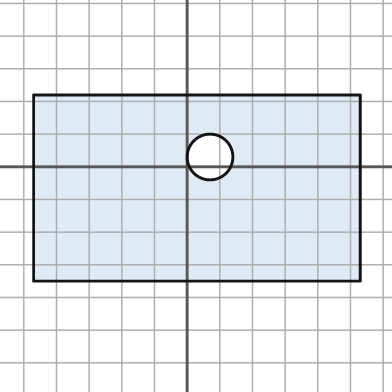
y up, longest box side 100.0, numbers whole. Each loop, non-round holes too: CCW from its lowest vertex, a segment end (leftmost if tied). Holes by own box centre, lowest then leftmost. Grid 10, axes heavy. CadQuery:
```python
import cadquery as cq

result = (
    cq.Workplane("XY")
    .moveTo(-47.0, -35.0)
    .lineTo(53.0, -35.0)
    .lineTo(53.0, 22.0)
    .lineTo(-47.0, 22.0)
    .close()
    .moveTo(7.0, 3.0)
    .circle(7.0)
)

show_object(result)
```